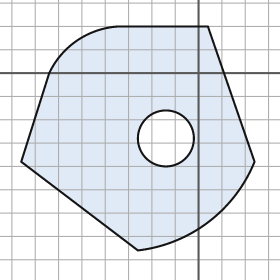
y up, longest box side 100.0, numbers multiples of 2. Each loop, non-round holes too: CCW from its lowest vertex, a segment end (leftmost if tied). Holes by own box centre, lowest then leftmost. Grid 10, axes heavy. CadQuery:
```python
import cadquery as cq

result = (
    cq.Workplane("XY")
    .moveTo(-26.0, -76.0)
    .threePointArc((4.0, -64.0), (24.0, -38.0))
    .lineTo(4.0, 20.0)
    .lineTo(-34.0, 20.0)
    .threePointArc((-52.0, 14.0), (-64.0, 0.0))
    .lineTo(-76.0, -38.0)
    .close()
    .moveTo(-14.0, -28.0)
    .circle(12.0)
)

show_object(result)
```